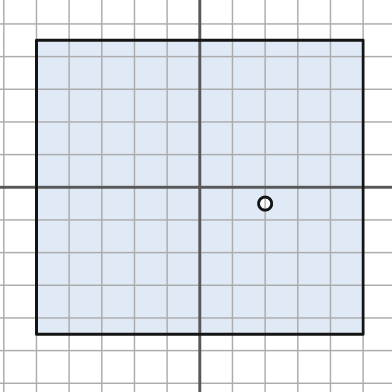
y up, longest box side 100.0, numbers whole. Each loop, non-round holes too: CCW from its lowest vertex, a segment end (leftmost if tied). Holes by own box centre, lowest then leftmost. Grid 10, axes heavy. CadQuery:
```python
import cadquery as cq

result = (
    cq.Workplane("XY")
    .moveTo(-50.0, -45.0)
    .lineTo(50.0, -45.0)
    .lineTo(50.0, 45.0)
    .lineTo(-50.0, 45.0)
    .close()
    .moveTo(20.0, -5.0)
    .circle(2.0)
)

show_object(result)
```